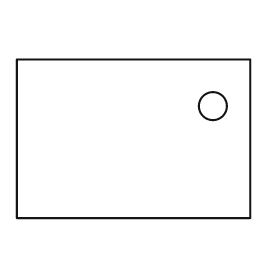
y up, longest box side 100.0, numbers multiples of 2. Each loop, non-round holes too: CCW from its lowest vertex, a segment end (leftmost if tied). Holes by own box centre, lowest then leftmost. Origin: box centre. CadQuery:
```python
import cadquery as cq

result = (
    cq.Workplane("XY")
    .moveTo(-50.0, -34.0)
    .lineTo(50.0, -34.0)
    .lineTo(50.0, 34.0)
    .lineTo(-50.0, 34.0)
    .close()
    .moveTo(34.0, 14.0)
    .circle(6.0)
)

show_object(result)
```